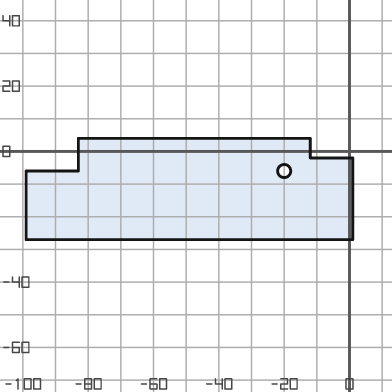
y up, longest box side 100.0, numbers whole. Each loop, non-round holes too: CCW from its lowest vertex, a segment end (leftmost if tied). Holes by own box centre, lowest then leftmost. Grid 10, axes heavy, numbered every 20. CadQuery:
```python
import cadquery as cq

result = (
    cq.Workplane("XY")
    .moveTo(-99.0, -27.0)
    .lineTo(1.0, -27.0)
    .lineTo(1.0, -2.0)
    .lineTo(-12.0, -2.0)
    .lineTo(-12.0, 4.0)
    .lineTo(-83.0, 4.0)
    .lineTo(-83.0, -6.0)
    .lineTo(-99.0, -6.0)
    .close()
    .moveTo(-20.0, -6.0)
    .circle(2.0)
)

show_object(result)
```